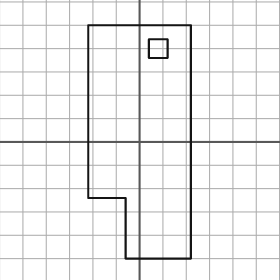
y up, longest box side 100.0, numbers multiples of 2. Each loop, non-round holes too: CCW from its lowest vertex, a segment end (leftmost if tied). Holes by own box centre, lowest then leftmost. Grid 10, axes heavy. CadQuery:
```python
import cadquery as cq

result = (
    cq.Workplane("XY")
    .moveTo(-6.0, -50.0)
    .lineTo(22.0, -50.0)
    .lineTo(22.0, 50.0)
    .lineTo(-22.0, 50.0)
    .lineTo(-22.0, -24.0)
    .lineTo(-6.0, -24.0)
    .close()
    .moveTo(4.0, 36.0)
    .lineTo(12.0, 36.0)
    .lineTo(12.0, 44.0)
    .lineTo(4.0, 44.0)
    .close()
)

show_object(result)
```